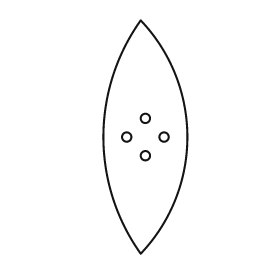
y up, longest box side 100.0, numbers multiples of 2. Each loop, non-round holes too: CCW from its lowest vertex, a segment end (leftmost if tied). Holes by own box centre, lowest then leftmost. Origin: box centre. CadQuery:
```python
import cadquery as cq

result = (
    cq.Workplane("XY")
    .moveTo(-2.0, -50.0)
    .threePointArc((18.0, 0.0), (-2.0, 50.0))
    .threePointArc((-18.0, 0.0), (-2.0, -50.0))
    .close()
    .moveTo(0.0, -8.0)
    .circle(2.0)
    .moveTo(-8.0, 0.0)
    .circle(2.0)
    .moveTo(8.0, 0.0)
    .circle(2.0)
    .moveTo(0.0, 8.0)
    .circle(2.0)
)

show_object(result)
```